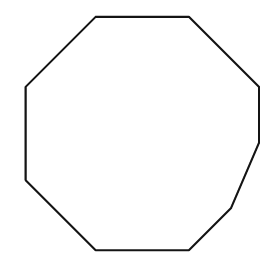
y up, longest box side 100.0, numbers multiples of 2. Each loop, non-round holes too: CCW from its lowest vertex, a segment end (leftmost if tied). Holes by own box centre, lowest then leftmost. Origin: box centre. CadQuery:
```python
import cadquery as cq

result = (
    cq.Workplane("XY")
    .moveTo(-20.0, -50.0)
    .lineTo(20.0, -50.0)
    .lineTo(38.0, -32.0)
    .lineTo(50.0, -4.0)
    .lineTo(50.0, 20.0)
    .lineTo(20.0, 50.0)
    .lineTo(-20.0, 50.0)
    .lineTo(-50.0, 20.0)
    .lineTo(-50.0, -20.0)
    .close()
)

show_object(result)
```